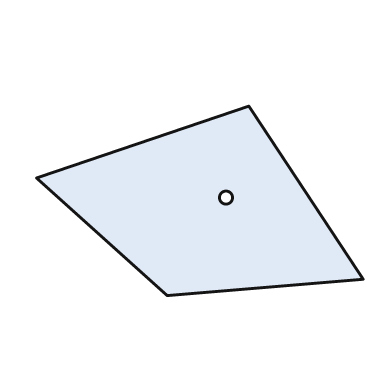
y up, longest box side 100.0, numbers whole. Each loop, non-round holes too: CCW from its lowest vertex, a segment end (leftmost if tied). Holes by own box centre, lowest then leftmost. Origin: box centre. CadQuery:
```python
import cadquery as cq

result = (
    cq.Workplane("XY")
    .moveTo(-10.0, -29.0)
    .lineTo(50.0, -24.0)
    .lineTo(15.0, 29.0)
    .lineTo(-50.0, 7.0)
    .close()
    .moveTo(8.0, 1.0)
    .circle(2.0)
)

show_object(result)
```